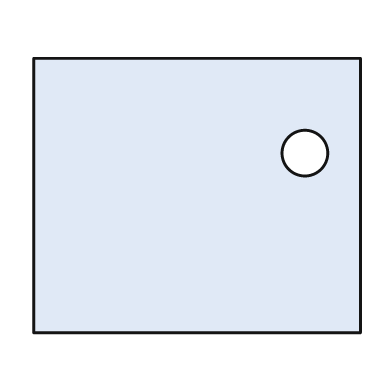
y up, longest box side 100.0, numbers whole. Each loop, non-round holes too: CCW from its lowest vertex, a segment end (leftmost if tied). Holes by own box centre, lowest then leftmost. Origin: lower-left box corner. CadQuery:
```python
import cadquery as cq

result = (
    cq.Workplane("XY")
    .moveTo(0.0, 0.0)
    .lineTo(100.0, 0.0)
    .lineTo(100.0, 84.0)
    .lineTo(0.0, 84.0)
    .close()
    .moveTo(83.0, 55.0)
    .circle(7.0)
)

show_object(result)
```